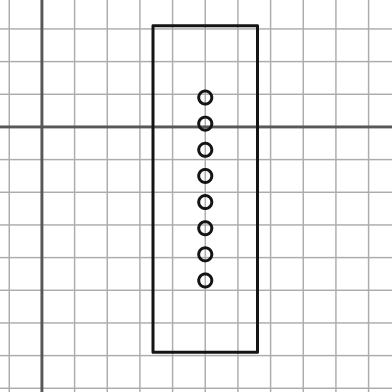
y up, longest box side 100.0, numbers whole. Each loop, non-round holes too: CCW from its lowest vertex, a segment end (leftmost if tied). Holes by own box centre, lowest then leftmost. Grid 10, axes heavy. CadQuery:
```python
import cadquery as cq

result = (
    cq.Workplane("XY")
    .moveTo(34.0, -69.0)
    .lineTo(66.0, -69.0)
    .lineTo(66.0, 31.0)
    .lineTo(34.0, 31.0)
    .close()
    .moveTo(50.0, -47.0)
    .circle(2.0)
    .moveTo(50.0, -39.0)
    .circle(2.0)
    .moveTo(50.0, -31.0)
    .circle(2.0)
    .moveTo(50.0, -23.0)
    .circle(2.0)
    .moveTo(50.0, -15.0)
    .circle(2.0)
    .moveTo(50.0, -7.0)
    .circle(2.0)
    .moveTo(50.0, 1.0)
    .circle(2.0)
    .moveTo(50.0, 9.0)
    .circle(2.0)
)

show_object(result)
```